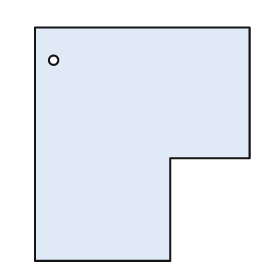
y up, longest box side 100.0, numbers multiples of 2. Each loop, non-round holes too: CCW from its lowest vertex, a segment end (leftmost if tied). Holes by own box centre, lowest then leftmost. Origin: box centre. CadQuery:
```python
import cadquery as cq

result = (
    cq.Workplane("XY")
    .moveTo(-46.0, -50.0)
    .lineTo(12.0, -50.0)
    .lineTo(12.0, -6.0)
    .lineTo(46.0, -6.0)
    .lineTo(46.0, 50.0)
    .lineTo(-46.0, 50.0)
    .close()
    .moveTo(-38.0, 36.0)
    .circle(2.0)
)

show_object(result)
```